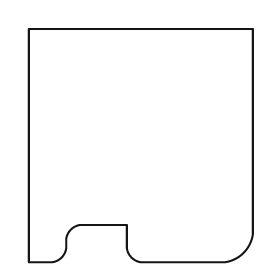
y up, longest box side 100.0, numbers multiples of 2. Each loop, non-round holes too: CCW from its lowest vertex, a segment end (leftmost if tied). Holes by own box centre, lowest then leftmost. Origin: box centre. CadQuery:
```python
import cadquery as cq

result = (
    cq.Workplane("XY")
    .moveTo(-48.0, -50.0)
    .lineTo(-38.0, -50.0)
    .threePointArc((-34.0, -48.0), (-32.0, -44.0))
    .lineTo(-32.0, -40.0)
    .threePointArc((-30.0, -36.0), (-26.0, -34.0))
    .lineTo(-6.0, -34.0)
    .lineTo(-6.0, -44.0)
    .threePointArc((-4.0, -48.0), (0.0, -50.0))
    .lineTo(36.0, -50.0)
    .threePointArc((44.0, -46.0), (48.0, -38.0))
    .lineTo(48.0, 50.0)
    .lineTo(-48.0, 50.0)
    .close()
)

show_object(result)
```